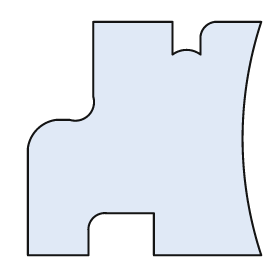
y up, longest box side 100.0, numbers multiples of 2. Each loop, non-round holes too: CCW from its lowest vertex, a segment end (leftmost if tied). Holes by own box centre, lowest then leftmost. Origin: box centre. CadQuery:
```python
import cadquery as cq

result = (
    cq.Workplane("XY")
    .moveTo(-50.0, -50.0)
    .lineTo(-24.0, -50.0)
    .lineTo(-24.0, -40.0)
    .threePointArc((-22.0, -34.0), (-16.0, -32.0))
    .lineTo(4.0, -32.0)
    .lineTo(4.0, -50.0)
    .lineTo(50.0, -50.0)
    .threePointArc((42.0, 0.0), (50.0, 50.0))
    .lineTo(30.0, 50.0)
    .threePointArc((26.0, 48.0), (24.0, 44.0))
    .lineTo(24.0, 36.0)
    .threePointArc((18.0, 38.0), (12.0, 36.0))
    .lineTo(12.0, 50.0)
    .lineTo(-22.0, 50.0)
    .lineTo(-22.0, 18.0)
    .threePointArc((-24.0, 10.0), (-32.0, 8.0))
    .lineTo(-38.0, 8.0)
    .threePointArc((-46.0, 4.0), (-50.0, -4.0))
    .close()
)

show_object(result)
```